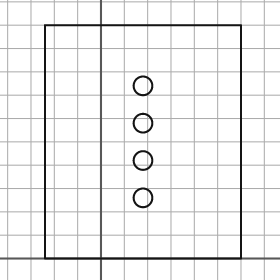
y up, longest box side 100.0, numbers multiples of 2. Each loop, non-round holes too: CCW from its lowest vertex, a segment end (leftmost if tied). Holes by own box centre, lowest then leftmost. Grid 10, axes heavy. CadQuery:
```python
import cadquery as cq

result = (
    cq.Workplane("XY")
    .moveTo(-24.0, 0.0)
    .lineTo(60.0, 0.0)
    .lineTo(60.0, 100.0)
    .lineTo(-24.0, 100.0)
    .close()
    .moveTo(18.0, 26.0)
    .circle(4.0)
    .moveTo(18.0, 42.0)
    .circle(4.0)
    .moveTo(18.0, 58.0)
    .circle(4.0)
    .moveTo(18.0, 74.0)
    .circle(4.0)
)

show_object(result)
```